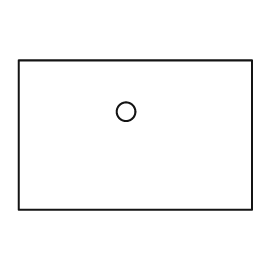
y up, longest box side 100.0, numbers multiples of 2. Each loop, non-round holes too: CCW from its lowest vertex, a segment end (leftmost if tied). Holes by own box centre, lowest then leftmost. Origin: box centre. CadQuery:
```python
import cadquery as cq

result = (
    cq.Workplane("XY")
    .moveTo(-50.0, -32.0)
    .lineTo(50.0, -32.0)
    .lineTo(50.0, 32.0)
    .lineTo(-50.0, 32.0)
    .close()
    .moveTo(-4.0, 10.0)
    .circle(4.0)
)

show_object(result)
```